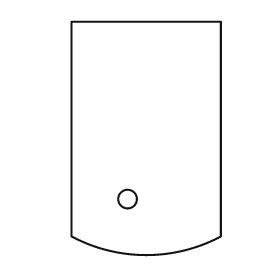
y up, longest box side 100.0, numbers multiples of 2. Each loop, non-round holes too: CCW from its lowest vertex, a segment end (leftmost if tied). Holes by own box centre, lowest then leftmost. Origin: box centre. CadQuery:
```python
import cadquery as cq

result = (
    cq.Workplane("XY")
    .moveTo(-32.0, -42.0)
    .threePointArc((0.0, -50.0), (32.0, -42.0))
    .lineTo(32.0, 50.0)
    .lineTo(-32.0, 50.0)
    .close()
    .moveTo(-8.0, -26.0)
    .circle(4.0)
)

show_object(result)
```